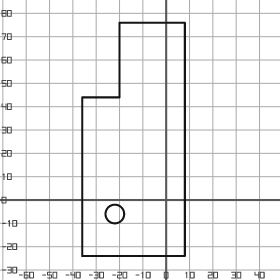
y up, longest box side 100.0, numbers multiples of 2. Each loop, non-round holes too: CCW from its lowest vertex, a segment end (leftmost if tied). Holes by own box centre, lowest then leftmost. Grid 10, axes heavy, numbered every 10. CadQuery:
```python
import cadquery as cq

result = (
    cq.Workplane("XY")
    .moveTo(-36.0, -24.0)
    .lineTo(8.0, -24.0)
    .lineTo(8.0, 76.0)
    .lineTo(-20.0, 76.0)
    .lineTo(-20.0, 44.0)
    .lineTo(-36.0, 44.0)
    .close()
    .moveTo(-22.0, -6.0)
    .circle(4.0)
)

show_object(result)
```